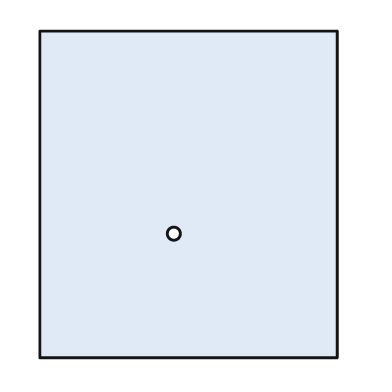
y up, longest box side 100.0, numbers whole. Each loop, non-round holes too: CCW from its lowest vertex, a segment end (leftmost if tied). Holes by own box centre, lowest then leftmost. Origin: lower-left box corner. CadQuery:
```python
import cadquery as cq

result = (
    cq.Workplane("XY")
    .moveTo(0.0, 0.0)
    .lineTo(91.0, 0.0)
    .lineTo(91.0, 100.0)
    .lineTo(0.0, 100.0)
    .close()
    .moveTo(41.0, 38.0)
    .circle(2.0)
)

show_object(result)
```